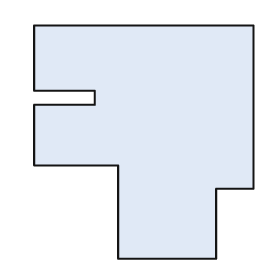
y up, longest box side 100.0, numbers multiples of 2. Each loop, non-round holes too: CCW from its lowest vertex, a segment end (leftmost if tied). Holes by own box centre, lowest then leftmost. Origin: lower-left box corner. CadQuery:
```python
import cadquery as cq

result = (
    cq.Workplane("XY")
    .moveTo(36.0, 0.0)
    .lineTo(78.0, 0.0)
    .lineTo(78.0, 30.0)
    .lineTo(94.0, 30.0)
    .lineTo(94.0, 100.0)
    .lineTo(0.0, 100.0)
    .lineTo(0.0, 72.0)
    .lineTo(26.0, 72.0)
    .lineTo(26.0, 66.0)
    .lineTo(0.0, 66.0)
    .lineTo(0.0, 40.0)
    .lineTo(36.0, 40.0)
    .close()
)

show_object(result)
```